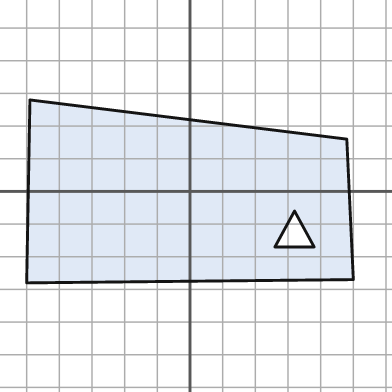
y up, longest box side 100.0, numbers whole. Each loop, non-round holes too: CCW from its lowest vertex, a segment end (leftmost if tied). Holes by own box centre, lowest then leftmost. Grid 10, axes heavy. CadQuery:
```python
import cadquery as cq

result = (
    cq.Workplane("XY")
    .moveTo(-50.0, -28.0)
    .lineTo(50.0, -27.0)
    .lineTo(48.0, 16.0)
    .lineTo(-49.0, 28.0)
    .close()
    .moveTo(26.0, -17.0)
    .lineTo(38.0, -17.0)
    .lineTo(32.0, -6.0)
    .close()
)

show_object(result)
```